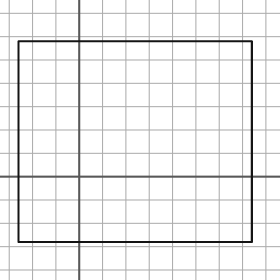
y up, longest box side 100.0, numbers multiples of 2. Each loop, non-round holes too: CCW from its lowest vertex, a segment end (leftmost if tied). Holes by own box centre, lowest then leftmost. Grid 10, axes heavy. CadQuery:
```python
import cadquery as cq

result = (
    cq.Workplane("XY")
    .moveTo(-26.0, -28.0)
    .lineTo(74.0, -28.0)
    .lineTo(74.0, 58.0)
    .lineTo(-26.0, 58.0)
    .close()
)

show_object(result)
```